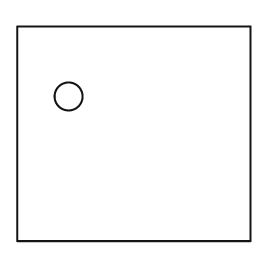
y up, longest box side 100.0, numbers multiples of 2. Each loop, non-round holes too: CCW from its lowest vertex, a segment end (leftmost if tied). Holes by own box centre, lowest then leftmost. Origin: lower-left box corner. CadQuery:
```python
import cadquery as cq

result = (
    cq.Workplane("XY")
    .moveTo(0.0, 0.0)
    .lineTo(100.0, 0.0)
    .lineTo(100.0, 92.0)
    .lineTo(0.0, 92.0)
    .close()
    .moveTo(22.0, 62.0)
    .circle(6.0)
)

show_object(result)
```